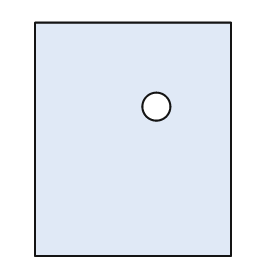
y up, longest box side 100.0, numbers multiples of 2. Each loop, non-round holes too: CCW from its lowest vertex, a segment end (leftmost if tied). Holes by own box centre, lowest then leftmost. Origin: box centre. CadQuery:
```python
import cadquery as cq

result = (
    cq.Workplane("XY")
    .moveTo(-42.0, -50.0)
    .lineTo(42.0, -50.0)
    .lineTo(42.0, 50.0)
    .lineTo(-42.0, 50.0)
    .close()
    .moveTo(10.0, 14.0)
    .circle(6.0)
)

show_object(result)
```